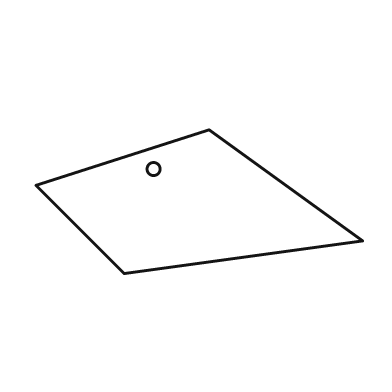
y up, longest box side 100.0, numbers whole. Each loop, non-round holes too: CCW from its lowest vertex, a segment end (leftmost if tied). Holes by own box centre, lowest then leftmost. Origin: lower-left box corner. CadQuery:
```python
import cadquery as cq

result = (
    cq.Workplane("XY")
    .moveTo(27.0, 0.0)
    .lineTo(100.0, 10.0)
    .lineTo(53.0, 44.0)
    .lineTo(0.0, 27.0)
    .close()
    .moveTo(36.0, 32.0)
    .circle(2.0)
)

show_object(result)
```